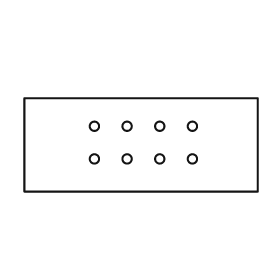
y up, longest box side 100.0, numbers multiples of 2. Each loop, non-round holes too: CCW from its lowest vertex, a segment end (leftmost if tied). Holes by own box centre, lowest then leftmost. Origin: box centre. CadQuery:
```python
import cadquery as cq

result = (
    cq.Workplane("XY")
    .moveTo(-50.0, -20.0)
    .lineTo(50.0, -20.0)
    .lineTo(50.0, 20.0)
    .lineTo(-50.0, 20.0)
    .close()
    .moveTo(-20.0, -6.0)
    .circle(2.0)
    .moveTo(-6.0, -6.0)
    .circle(2.0)
    .moveTo(8.0, -6.0)
    .circle(2.0)
    .moveTo(22.0, -6.0)
    .circle(2.0)
    .moveTo(-20.0, 8.0)
    .circle(2.0)
    .moveTo(-6.0, 8.0)
    .circle(2.0)
    .moveTo(8.0, 8.0)
    .circle(2.0)
    .moveTo(22.0, 8.0)
    .circle(2.0)
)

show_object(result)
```